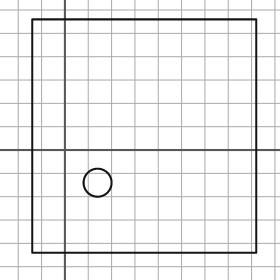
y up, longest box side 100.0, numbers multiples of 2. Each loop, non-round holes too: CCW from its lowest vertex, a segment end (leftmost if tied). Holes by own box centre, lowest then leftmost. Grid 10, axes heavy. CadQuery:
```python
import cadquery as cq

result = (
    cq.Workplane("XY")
    .moveTo(-14.0, -44.0)
    .lineTo(82.0, -44.0)
    .lineTo(82.0, 56.0)
    .lineTo(-14.0, 56.0)
    .close()
    .moveTo(14.0, -14.0)
    .circle(6.0)
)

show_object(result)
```